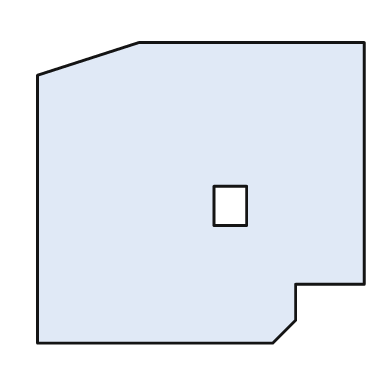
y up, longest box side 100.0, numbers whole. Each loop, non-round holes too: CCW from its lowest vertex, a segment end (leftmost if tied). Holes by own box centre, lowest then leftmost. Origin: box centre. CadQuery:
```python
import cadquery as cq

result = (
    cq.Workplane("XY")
    .moveTo(-50.0, -46.0)
    .lineTo(22.0, -46.0)
    .lineTo(29.0, -39.0)
    .lineTo(29.0, -28.0)
    .lineTo(50.0, -28.0)
    .lineTo(50.0, 46.0)
    .lineTo(-19.0, 46.0)
    .lineTo(-50.0, 36.0)
    .close()
    .moveTo(4.0, -10.0)
    .lineTo(14.0, -10.0)
    .lineTo(14.0, 2.0)
    .lineTo(4.0, 2.0)
    .close()
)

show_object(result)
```